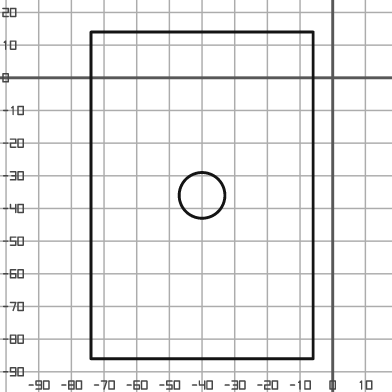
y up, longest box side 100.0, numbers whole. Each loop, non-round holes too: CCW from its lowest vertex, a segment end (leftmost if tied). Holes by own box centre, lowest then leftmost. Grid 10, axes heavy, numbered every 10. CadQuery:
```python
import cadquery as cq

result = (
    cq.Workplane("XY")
    .moveTo(-74.0, -86.0)
    .lineTo(-6.0, -86.0)
    .lineTo(-6.0, 14.0)
    .lineTo(-74.0, 14.0)
    .close()
    .moveTo(-40.0, -36.0)
    .circle(7.0)
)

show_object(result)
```